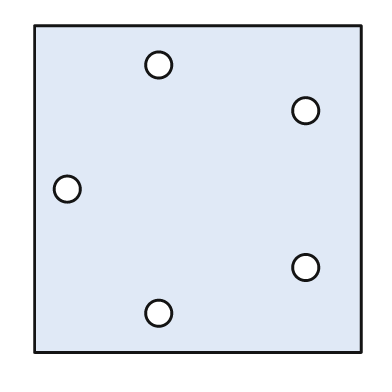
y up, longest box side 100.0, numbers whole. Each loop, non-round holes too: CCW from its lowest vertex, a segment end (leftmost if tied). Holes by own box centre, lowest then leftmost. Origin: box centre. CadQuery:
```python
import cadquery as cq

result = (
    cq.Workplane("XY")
    .moveTo(-50.0, -50.0)
    .lineTo(50.0, -50.0)
    .lineTo(50.0, 50.0)
    .lineTo(-50.0, 50.0)
    .close()
    .moveTo(-12.0, -38.0)
    .circle(4.0)
    .moveTo(33.0, -24.0)
    .circle(4.0)
    .moveTo(-40.0, 0.0)
    .circle(4.0)
    .moveTo(33.0, 24.0)
    .circle(4.0)
    .moveTo(-12.0, 38.0)
    .circle(4.0)
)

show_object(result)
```